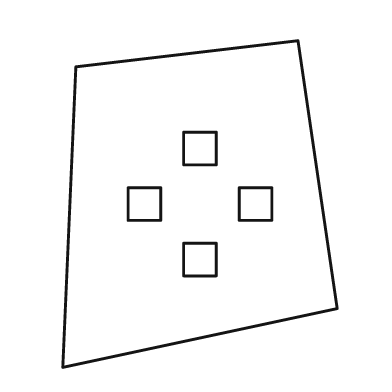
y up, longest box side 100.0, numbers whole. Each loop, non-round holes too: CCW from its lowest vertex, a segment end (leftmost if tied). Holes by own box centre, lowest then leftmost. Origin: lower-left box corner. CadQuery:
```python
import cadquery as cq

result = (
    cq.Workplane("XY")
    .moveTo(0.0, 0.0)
    .lineTo(84.0, 18.0)
    .lineTo(72.0, 100.0)
    .lineTo(4.0, 92.0)
    .close()
    .moveTo(37.0, 28.0)
    .lineTo(47.0, 28.0)
    .lineTo(47.0, 38.0)
    .lineTo(37.0, 38.0)
    .close()
    .moveTo(20.0, 45.0)
    .lineTo(30.0, 45.0)
    .lineTo(30.0, 55.0)
    .lineTo(20.0, 55.0)
    .close()
    .moveTo(54.0, 45.0)
    .lineTo(64.0, 45.0)
    .lineTo(64.0, 55.0)
    .lineTo(54.0, 55.0)
    .close()
    .moveTo(37.0, 62.0)
    .lineTo(47.0, 62.0)
    .lineTo(47.0, 72.0)
    .lineTo(37.0, 72.0)
    .close()
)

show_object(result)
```